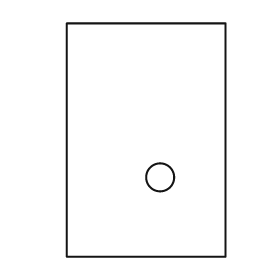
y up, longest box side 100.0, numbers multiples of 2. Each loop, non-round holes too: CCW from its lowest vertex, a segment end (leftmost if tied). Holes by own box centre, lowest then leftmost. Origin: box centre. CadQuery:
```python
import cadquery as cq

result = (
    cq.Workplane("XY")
    .moveTo(-34.0, -50.0)
    .lineTo(34.0, -50.0)
    .lineTo(34.0, 50.0)
    .lineTo(-34.0, 50.0)
    .close()
    .moveTo(6.0, -16.0)
    .circle(6.0)
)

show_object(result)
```